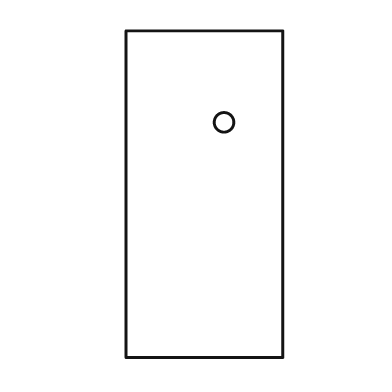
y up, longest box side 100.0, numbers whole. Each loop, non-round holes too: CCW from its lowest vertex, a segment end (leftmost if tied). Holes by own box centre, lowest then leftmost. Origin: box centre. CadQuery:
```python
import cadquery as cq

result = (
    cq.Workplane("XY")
    .moveTo(-24.0, -50.0)
    .lineTo(24.0, -50.0)
    .lineTo(24.0, 50.0)
    .lineTo(-24.0, 50.0)
    .close()
    .moveTo(6.0, 22.0)
    .circle(3.0)
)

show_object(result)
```